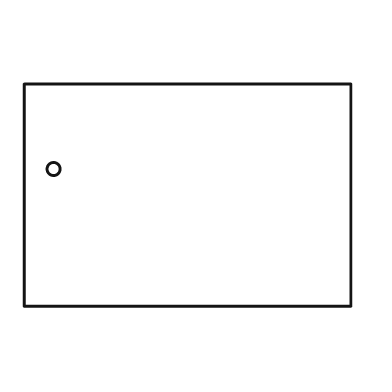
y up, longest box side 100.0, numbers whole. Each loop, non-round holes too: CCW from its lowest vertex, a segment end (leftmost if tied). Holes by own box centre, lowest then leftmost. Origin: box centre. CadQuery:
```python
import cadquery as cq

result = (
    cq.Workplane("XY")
    .moveTo(-50.0, -34.0)
    .lineTo(50.0, -34.0)
    .lineTo(50.0, 34.0)
    .lineTo(-50.0, 34.0)
    .close()
    .moveTo(-41.0, 8.0)
    .circle(2.0)
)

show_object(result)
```